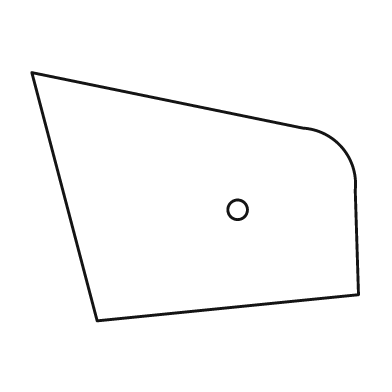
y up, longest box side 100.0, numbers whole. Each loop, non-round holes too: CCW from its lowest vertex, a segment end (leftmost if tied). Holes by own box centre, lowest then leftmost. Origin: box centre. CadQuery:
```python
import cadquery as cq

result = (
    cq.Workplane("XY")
    .moveTo(-30.0, -38.0)
    .lineTo(50.0, -30.0)
    .lineTo(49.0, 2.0)
    .threePointArc((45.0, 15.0), (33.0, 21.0))
    .lineTo(-50.0, 38.0)
    .close()
    .moveTo(13.0, -4.0)
    .circle(3.0)
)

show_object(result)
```